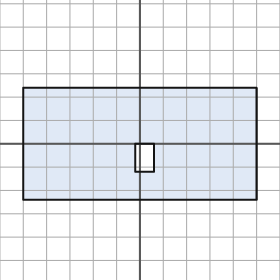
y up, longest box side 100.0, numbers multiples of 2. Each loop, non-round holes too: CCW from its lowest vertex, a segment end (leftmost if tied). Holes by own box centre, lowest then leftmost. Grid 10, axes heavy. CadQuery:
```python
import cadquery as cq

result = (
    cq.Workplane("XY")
    .moveTo(-50.0, -24.0)
    .lineTo(50.0, -24.0)
    .lineTo(50.0, 24.0)
    .lineTo(-50.0, 24.0)
    .close()
    .moveTo(-2.0, -12.0)
    .lineTo(6.0, -12.0)
    .lineTo(6.0, 0.0)
    .lineTo(-2.0, 0.0)
    .close()
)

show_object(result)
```